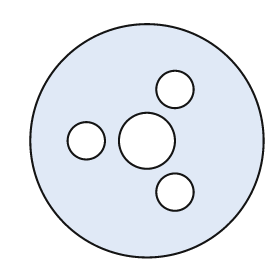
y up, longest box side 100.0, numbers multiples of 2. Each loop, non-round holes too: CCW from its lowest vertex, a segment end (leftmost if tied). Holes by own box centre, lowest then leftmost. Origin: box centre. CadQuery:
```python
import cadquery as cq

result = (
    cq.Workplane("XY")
    .moveTo(0.0, 0.0)
    .circle(50.0)
    .moveTo(12.0, -22.0)
    .circle(8.0)
    .moveTo(-26.0, 0.0)
    .circle(8.0)
    .moveTo(0.0, 0.0)
    .circle(12.0)
    .moveTo(12.0, 22.0)
    .circle(8.0)
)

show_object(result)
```